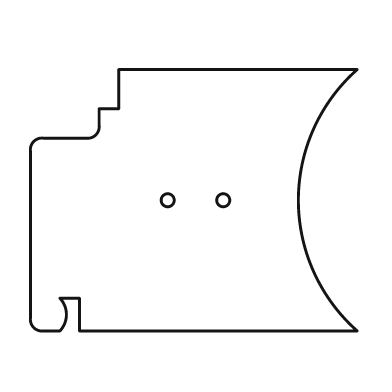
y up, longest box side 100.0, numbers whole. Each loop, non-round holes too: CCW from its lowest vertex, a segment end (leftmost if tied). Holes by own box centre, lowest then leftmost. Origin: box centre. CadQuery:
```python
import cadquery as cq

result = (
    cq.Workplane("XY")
    .moveTo(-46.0, -40.0)
    .lineTo(-41.0, -40.0)
    .threePointArc((-39.0, -35.0), (-41.0, -30.0))
    .lineTo(-35.0, -30.0)
    .lineTo(-35.0, -40.0)
    .lineTo(50.0, -40.0)
    .threePointArc((32.0, 0.0), (50.0, 40.0))
    .lineTo(-23.0, 40.0)
    .lineTo(-23.0, 28.0)
    .lineTo(-29.0, 28.0)
    .lineTo(-29.0, 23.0)
    .threePointArc((-30.0, 20.0), (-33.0, 19.0))
    .lineTo(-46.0, 19.0)
    .threePointArc((-49.0, 18.0), (-50.0, 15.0))
    .lineTo(-50.0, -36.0)
    .threePointArc((-49.0, -39.0), (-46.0, -40.0))
    .close()
    .moveTo(-8.0, 0.0)
    .circle(2.0)
    .moveTo(9.0, 0.0)
    .circle(2.0)
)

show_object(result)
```